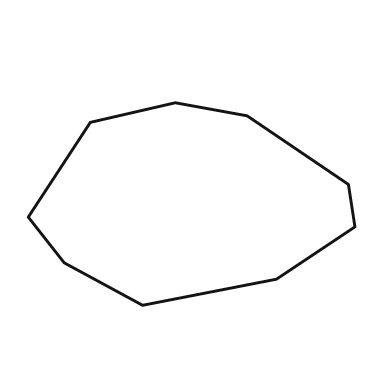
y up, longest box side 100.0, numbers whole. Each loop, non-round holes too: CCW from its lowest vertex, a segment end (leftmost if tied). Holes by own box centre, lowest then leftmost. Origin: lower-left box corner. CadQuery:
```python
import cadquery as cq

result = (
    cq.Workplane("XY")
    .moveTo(35.0, 0.0)
    .lineTo(76.0, 8.0)
    .lineTo(100.0, 24.0)
    .lineTo(98.0, 37.0)
    .lineTo(67.0, 58.0)
    .lineTo(45.0, 62.0)
    .lineTo(19.0, 56.0)
    .lineTo(0.0, 27.0)
    .lineTo(11.0, 13.0)
    .close()
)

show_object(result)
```